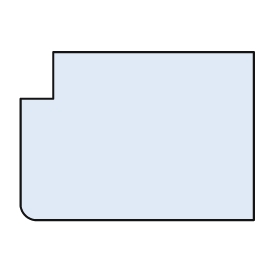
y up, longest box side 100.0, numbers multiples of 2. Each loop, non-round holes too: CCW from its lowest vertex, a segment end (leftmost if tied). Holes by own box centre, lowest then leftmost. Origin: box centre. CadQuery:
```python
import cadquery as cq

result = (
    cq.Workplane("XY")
    .moveTo(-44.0, -36.0)
    .lineTo(50.0, -36.0)
    .lineTo(50.0, 36.0)
    .lineTo(-36.0, 36.0)
    .lineTo(-36.0, 16.0)
    .lineTo(-50.0, 16.0)
    .lineTo(-50.0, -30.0)
    .threePointArc((-48.0, -34.0), (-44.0, -36.0))
    .close()
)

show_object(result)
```